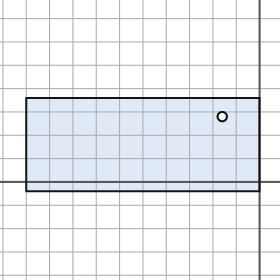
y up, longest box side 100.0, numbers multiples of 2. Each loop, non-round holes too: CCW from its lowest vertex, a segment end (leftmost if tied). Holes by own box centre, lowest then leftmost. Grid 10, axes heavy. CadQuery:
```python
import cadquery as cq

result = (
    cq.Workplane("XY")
    .moveTo(-100.0, -4.0)
    .lineTo(0.0, -4.0)
    .lineTo(0.0, 36.0)
    .lineTo(-100.0, 36.0)
    .close()
    .moveTo(-16.0, 28.0)
    .circle(2.0)
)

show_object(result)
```